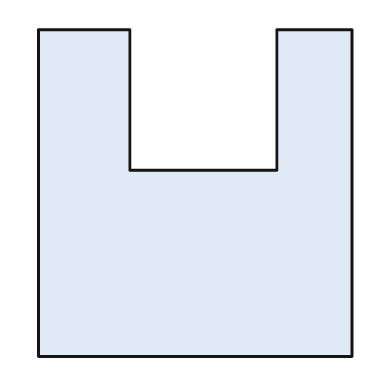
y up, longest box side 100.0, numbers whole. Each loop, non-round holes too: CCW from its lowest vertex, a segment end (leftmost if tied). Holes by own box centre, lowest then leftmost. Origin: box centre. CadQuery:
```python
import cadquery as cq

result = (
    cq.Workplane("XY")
    .moveTo(-48.0, -50.0)
    .lineTo(48.0, -50.0)
    .lineTo(48.0, 50.0)
    .lineTo(25.0, 50.0)
    .lineTo(25.0, 7.0)
    .lineTo(-20.0, 7.0)
    .lineTo(-20.0, 50.0)
    .lineTo(-48.0, 50.0)
    .close()
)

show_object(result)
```